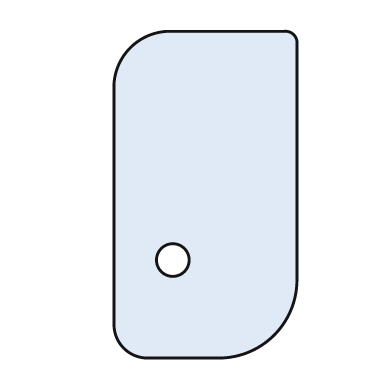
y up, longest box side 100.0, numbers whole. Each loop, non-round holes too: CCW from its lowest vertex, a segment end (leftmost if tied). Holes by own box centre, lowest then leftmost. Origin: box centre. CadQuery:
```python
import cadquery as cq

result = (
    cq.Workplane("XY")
    .moveTo(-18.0, -50.0)
    .lineTo(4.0, -50.0)
    .threePointArc((21.0, -43.0), (28.0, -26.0))
    .lineTo(28.0, 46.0)
    .threePointArc((27.0, 49.0), (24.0, 50.0))
    .lineTo(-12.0, 50.0)
    .threePointArc((-23.0, 45.0), (-28.0, 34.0))
    .lineTo(-28.0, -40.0)
    .threePointArc((-25.0, -47.0), (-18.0, -50.0))
    .close()
    .moveTo(-10.0, -20.0)
    .circle(5.0)
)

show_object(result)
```